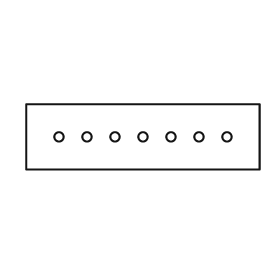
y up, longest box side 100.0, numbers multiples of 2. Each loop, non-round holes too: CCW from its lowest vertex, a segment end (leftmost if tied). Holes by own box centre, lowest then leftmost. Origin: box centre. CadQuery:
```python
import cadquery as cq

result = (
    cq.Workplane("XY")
    .moveTo(-50.0, -14.0)
    .lineTo(50.0, -14.0)
    .lineTo(50.0, 14.0)
    .lineTo(-50.0, 14.0)
    .close()
    .moveTo(-36.0, 0.0)
    .circle(2.0)
    .moveTo(-24.0, 0.0)
    .circle(2.0)
    .moveTo(-12.0, 0.0)
    .circle(2.0)
    .moveTo(0.0, 0.0)
    .circle(2.0)
    .moveTo(12.0, 0.0)
    .circle(2.0)
    .moveTo(24.0, 0.0)
    .circle(2.0)
    .moveTo(36.0, 0.0)
    .circle(2.0)
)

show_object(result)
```